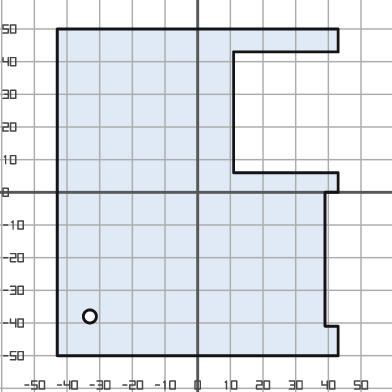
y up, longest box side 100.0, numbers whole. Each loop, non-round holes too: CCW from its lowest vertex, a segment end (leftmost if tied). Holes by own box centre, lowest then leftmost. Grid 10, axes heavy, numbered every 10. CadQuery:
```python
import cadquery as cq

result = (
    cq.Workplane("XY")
    .moveTo(-43.0, -50.0)
    .lineTo(43.0, -50.0)
    .lineTo(43.0, -41.0)
    .lineTo(39.0, -41.0)
    .lineTo(39.0, 0.0)
    .lineTo(43.0, 0.0)
    .lineTo(43.0, 6.0)
    .lineTo(11.0, 6.0)
    .lineTo(11.0, 43.0)
    .lineTo(43.0, 43.0)
    .lineTo(43.0, 50.0)
    .lineTo(-43.0, 50.0)
    .close()
    .moveTo(-33.0, -38.0)
    .circle(2.0)
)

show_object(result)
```